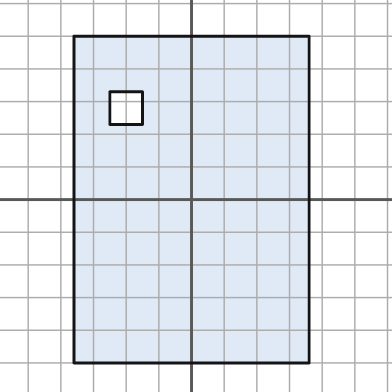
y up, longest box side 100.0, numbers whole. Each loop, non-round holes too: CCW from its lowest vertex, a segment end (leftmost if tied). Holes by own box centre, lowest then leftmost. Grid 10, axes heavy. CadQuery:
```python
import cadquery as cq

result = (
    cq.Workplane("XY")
    .moveTo(-36.0, -50.0)
    .lineTo(36.0, -50.0)
    .lineTo(36.0, 50.0)
    .lineTo(-36.0, 50.0)
    .close()
    .moveTo(-25.0, 23.0)
    .lineTo(-15.0, 23.0)
    .lineTo(-15.0, 33.0)
    .lineTo(-25.0, 33.0)
    .close()
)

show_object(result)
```